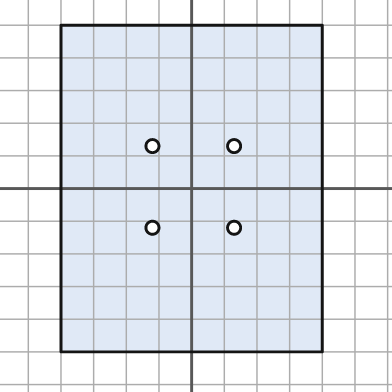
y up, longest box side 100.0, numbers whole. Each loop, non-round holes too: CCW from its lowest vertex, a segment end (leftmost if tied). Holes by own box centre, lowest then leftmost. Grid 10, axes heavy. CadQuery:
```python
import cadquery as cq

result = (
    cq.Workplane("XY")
    .moveTo(-40.0, -50.0)
    .lineTo(40.0, -50.0)
    .lineTo(40.0, 50.0)
    .lineTo(-40.0, 50.0)
    .close()
    .moveTo(-12.0, -12.0)
    .circle(2.0)
    .moveTo(13.0, -12.0)
    .circle(2.0)
    .moveTo(-12.0, 13.0)
    .circle(2.0)
    .moveTo(13.0, 13.0)
    .circle(2.0)
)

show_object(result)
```